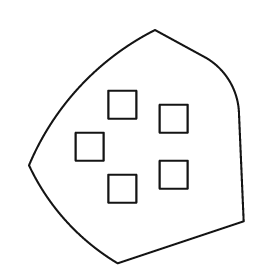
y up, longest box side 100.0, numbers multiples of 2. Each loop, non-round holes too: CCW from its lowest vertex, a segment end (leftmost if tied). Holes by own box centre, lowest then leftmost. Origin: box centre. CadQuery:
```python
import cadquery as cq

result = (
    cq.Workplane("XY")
    .moveTo(-8.0, -50.0)
    .lineTo(46.0, -32.0)
    .lineTo(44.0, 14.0)
    .threePointArc((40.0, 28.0), (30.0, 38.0))
    .lineTo(8.0, 50.0)
    .threePointArc((-24.0, 26.0), (-46.0, -8.0))
    .threePointArc((-30.0, -32.0), (-8.0, -50.0))
    .close()
    .moveTo(-12.0, -24.0)
    .lineTo(0.0, -24.0)
    .lineTo(0.0, -12.0)
    .lineTo(-12.0, -12.0)
    .close()
    .moveTo(10.0, -18.0)
    .lineTo(22.0, -18.0)
    .lineTo(22.0, -6.0)
    .lineTo(10.0, -6.0)
    .close()
    .moveTo(-26.0, -6.0)
    .lineTo(-14.0, -6.0)
    .lineTo(-14.0, 6.0)
    .lineTo(-26.0, 6.0)
    .close()
    .moveTo(10.0, 6.0)
    .lineTo(22.0, 6.0)
    .lineTo(22.0, 18.0)
    .lineTo(10.0, 18.0)
    .close()
    .moveTo(-12.0, 12.0)
    .lineTo(0.0, 12.0)
    .lineTo(0.0, 24.0)
    .lineTo(-12.0, 24.0)
    .close()
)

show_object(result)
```